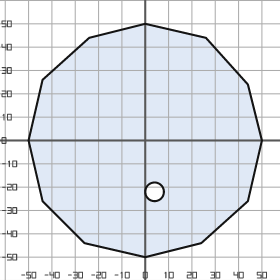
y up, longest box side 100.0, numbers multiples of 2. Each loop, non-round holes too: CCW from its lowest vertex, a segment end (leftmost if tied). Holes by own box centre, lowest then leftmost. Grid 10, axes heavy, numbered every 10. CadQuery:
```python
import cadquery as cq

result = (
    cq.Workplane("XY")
    .moveTo(0.0, -50.0)
    .lineTo(24.0, -44.0)
    .lineTo(44.0, -26.0)
    .lineTo(50.0, 0.0)
    .lineTo(44.0, 24.0)
    .lineTo(26.0, 44.0)
    .lineTo(0.0, 50.0)
    .lineTo(-24.0, 44.0)
    .lineTo(-44.0, 26.0)
    .lineTo(-50.0, 0.0)
    .lineTo(-44.0, -26.0)
    .lineTo(-26.0, -44.0)
    .close()
    .moveTo(4.0, -22.0)
    .circle(4.0)
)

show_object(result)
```